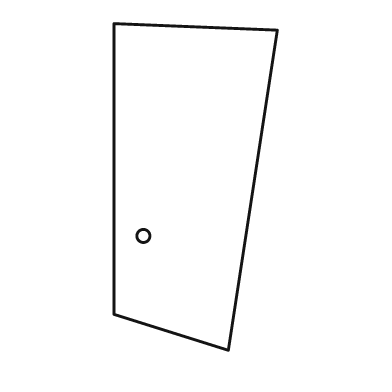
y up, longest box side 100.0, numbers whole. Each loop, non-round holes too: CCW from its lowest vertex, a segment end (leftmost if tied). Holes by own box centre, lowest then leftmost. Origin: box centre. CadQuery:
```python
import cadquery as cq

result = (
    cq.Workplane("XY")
    .moveTo(10.0, -50.0)
    .lineTo(25.0, 48.0)
    .lineTo(-25.0, 50.0)
    .lineTo(-25.0, -39.0)
    .close()
    .moveTo(-16.0, -15.0)
    .circle(2.0)
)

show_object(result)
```